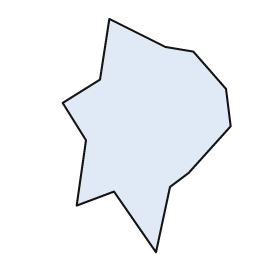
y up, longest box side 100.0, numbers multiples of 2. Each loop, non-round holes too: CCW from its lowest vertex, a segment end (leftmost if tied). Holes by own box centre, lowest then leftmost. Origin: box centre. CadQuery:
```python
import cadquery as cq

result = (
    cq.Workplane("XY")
    .moveTo(4.0, -50.0)
    .lineTo(10.0, -22.0)
    .lineTo(18.0, -16.0)
    .lineTo(36.0, 4.0)
    .lineTo(34.0, 20.0)
    .lineTo(20.0, 36.0)
    .lineTo(8.0, 38.0)
    .lineTo(-16.0, 50.0)
    .lineTo(-20.0, 24.0)
    .lineTo(-36.0, 14.0)
    .lineTo(-26.0, -2.0)
    .lineTo(-30.0, -30.0)
    .lineTo(-14.0, -24.0)
    .close()
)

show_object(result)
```